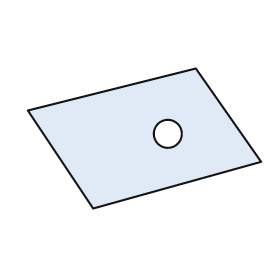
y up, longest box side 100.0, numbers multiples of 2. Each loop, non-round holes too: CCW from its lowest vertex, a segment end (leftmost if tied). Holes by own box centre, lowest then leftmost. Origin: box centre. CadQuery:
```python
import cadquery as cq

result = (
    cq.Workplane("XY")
    .moveTo(-22.0, -30.0)
    .lineTo(50.0, -10.0)
    .lineTo(22.0, 30.0)
    .lineTo(-50.0, 12.0)
    .close()
    .moveTo(10.0, 2.0)
    .circle(6.0)
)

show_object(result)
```